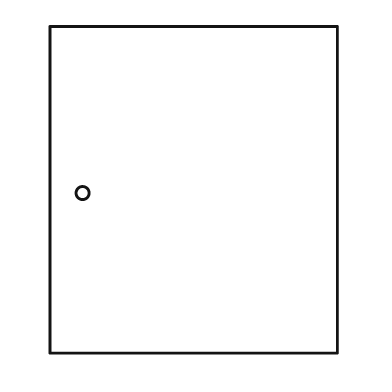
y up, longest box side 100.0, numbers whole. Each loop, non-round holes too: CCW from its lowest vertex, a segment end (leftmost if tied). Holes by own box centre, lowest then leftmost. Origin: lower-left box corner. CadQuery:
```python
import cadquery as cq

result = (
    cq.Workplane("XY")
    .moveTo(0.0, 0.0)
    .lineTo(88.0, 0.0)
    .lineTo(88.0, 100.0)
    .lineTo(0.0, 100.0)
    .close()
    .moveTo(10.0, 49.0)
    .circle(2.0)
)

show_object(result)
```